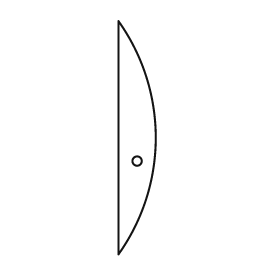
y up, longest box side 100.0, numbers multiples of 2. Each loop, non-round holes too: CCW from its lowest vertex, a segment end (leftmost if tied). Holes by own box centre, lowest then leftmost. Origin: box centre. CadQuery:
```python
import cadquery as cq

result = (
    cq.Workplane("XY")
    .moveTo(-8.0, -50.0)
    .threePointArc((8.0, 0.0), (-8.0, 50.0))
    .close()
    .moveTo(0.0, -10.0)
    .circle(2.0)
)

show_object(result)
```